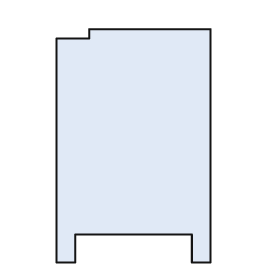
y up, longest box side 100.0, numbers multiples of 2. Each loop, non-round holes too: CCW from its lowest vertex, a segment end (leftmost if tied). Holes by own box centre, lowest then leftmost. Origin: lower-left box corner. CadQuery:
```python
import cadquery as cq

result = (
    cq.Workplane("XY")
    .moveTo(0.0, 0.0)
    .lineTo(8.0, 0.0)
    .lineTo(8.0, 12.0)
    .lineTo(58.0, 12.0)
    .lineTo(58.0, 0.0)
    .lineTo(66.0, 0.0)
    .lineTo(66.0, 100.0)
    .lineTo(14.0, 100.0)
    .lineTo(14.0, 96.0)
    .lineTo(0.0, 96.0)
    .close()
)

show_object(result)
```